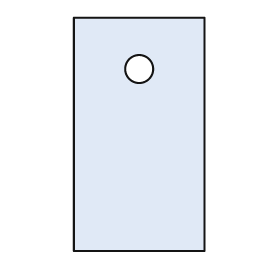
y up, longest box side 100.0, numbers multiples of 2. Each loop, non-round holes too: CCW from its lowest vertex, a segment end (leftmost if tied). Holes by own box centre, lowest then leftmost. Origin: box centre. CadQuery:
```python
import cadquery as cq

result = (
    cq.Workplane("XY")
    .moveTo(-28.0, -50.0)
    .lineTo(28.0, -50.0)
    .lineTo(28.0, 50.0)
    .lineTo(-28.0, 50.0)
    .close()
    .moveTo(0.0, 28.0)
    .circle(6.0)
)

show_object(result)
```